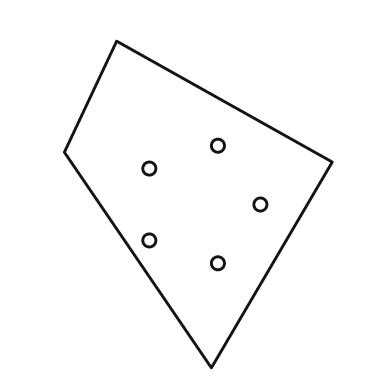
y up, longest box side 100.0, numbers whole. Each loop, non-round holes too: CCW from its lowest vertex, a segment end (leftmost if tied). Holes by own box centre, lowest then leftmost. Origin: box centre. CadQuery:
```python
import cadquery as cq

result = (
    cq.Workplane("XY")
    .moveTo(4.0, -50.0)
    .lineTo(41.0, 13.0)
    .lineTo(-25.0, 50.0)
    .lineTo(-41.0, 16.0)
    .close()
    .moveTo(6.0, -18.0)
    .circle(2.0)
    .moveTo(-15.0, -11.0)
    .circle(2.0)
    .moveTo(19.0, 0.0)
    .circle(2.0)
    .moveTo(-15.0, 11.0)
    .circle(2.0)
    .moveTo(6.0, 18.0)
    .circle(2.0)
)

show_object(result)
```